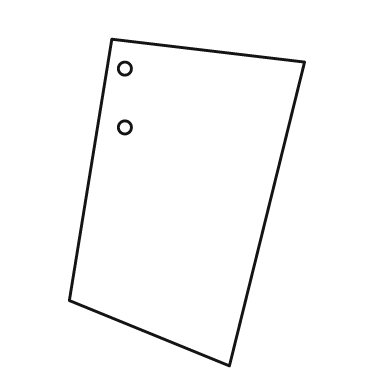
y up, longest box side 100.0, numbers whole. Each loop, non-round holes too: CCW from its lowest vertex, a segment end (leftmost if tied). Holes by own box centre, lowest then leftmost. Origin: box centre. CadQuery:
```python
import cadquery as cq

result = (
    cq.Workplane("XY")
    .moveTo(13.0, -50.0)
    .lineTo(36.0, 43.0)
    .lineTo(-23.0, 50.0)
    .lineTo(-36.0, -30.0)
    .close()
    .moveTo(-19.0, 23.0)
    .circle(2.0)
    .moveTo(-19.0, 41.0)
    .circle(2.0)
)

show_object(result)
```